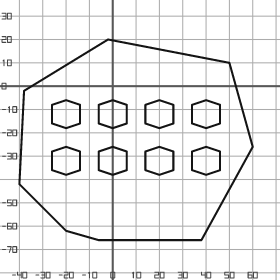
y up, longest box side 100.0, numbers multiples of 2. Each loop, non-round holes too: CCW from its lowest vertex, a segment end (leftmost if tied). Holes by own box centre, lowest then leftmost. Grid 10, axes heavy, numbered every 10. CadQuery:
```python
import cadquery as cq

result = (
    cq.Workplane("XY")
    .moveTo(-6.0, -66.0)
    .lineTo(38.0, -66.0)
    .lineTo(60.0, -26.0)
    .lineTo(50.0, 10.0)
    .lineTo(-2.0, 20.0)
    .lineTo(-38.0, -2.0)
    .lineTo(-40.0, -42.0)
    .lineTo(-20.0, -62.0)
    .close()
    .moveTo(-20.0, -38.0)
    .lineTo(-14.0, -36.0)
    .lineTo(-14.0, -28.0)
    .lineTo(-20.0, -26.0)
    .lineTo(-26.0, -28.0)
    .lineTo(-26.0, -36.0)
    .close()
    .moveTo(0.0, -38.0)
    .lineTo(6.0, -36.0)
    .lineTo(6.0, -28.0)
    .lineTo(0.0, -26.0)
    .lineTo(-6.0, -28.0)
    .lineTo(-6.0, -36.0)
    .close()
    .moveTo(20.0, -38.0)
    .lineTo(26.0, -36.0)
    .lineTo(26.0, -28.0)
    .lineTo(20.0, -26.0)
    .lineTo(14.0, -28.0)
    .lineTo(14.0, -36.0)
    .close()
    .moveTo(40.0, -38.0)
    .lineTo(46.0, -36.0)
    .lineTo(46.0, -28.0)
    .lineTo(40.0, -26.0)
    .lineTo(34.0, -28.0)
    .lineTo(34.0, -36.0)
    .close()
    .moveTo(-20.0, -18.0)
    .lineTo(-14.0, -16.0)
    .lineTo(-14.0, -8.0)
    .lineTo(-20.0, -6.0)
    .lineTo(-26.0, -8.0)
    .lineTo(-26.0, -16.0)
    .close()
    .moveTo(0.0, -18.0)
    .lineTo(6.0, -16.0)
    .lineTo(6.0, -8.0)
    .lineTo(0.0, -6.0)
    .lineTo(-6.0, -8.0)
    .lineTo(-6.0, -16.0)
    .close()
    .moveTo(20.0, -18.0)
    .lineTo(26.0, -16.0)
    .lineTo(26.0, -8.0)
    .lineTo(20.0, -6.0)
    .lineTo(14.0, -8.0)
    .lineTo(14.0, -16.0)
    .close()
    .moveTo(40.0, -18.0)
    .lineTo(46.0, -16.0)
    .lineTo(46.0, -8.0)
    .lineTo(40.0, -6.0)
    .lineTo(34.0, -8.0)
    .lineTo(34.0, -16.0)
    .close()
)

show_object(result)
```